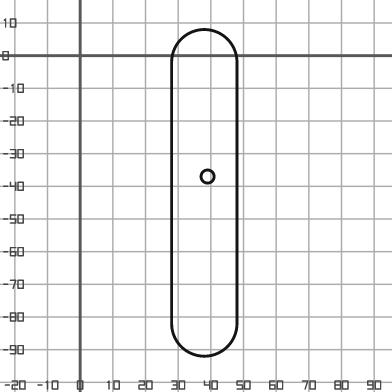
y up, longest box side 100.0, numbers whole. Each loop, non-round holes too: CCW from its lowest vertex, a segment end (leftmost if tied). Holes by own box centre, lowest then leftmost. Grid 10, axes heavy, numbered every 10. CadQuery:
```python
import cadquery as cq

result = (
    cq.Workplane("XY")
    .moveTo(28.0, -82.0)
    .threePointArc((38.0, -92.0), (48.0, -82.0))
    .lineTo(48.0, -2.0)
    .threePointArc((38.0, 8.0), (28.0, -2.0))
    .close()
    .moveTo(39.0, -37.0)
    .circle(2.0)
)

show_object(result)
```